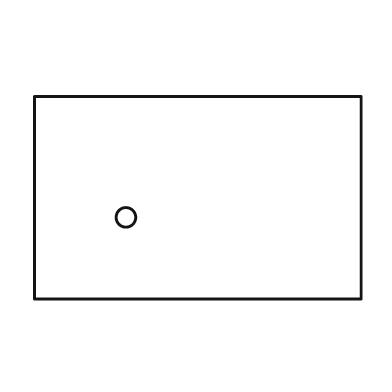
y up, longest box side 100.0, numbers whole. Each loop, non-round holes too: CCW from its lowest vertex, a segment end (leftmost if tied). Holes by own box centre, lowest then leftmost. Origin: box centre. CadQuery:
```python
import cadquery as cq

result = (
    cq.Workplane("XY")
    .moveTo(-50.0, -31.0)
    .lineTo(50.0, -31.0)
    .lineTo(50.0, 31.0)
    .lineTo(-50.0, 31.0)
    .close()
    .moveTo(-22.0, -6.0)
    .circle(3.0)
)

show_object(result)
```